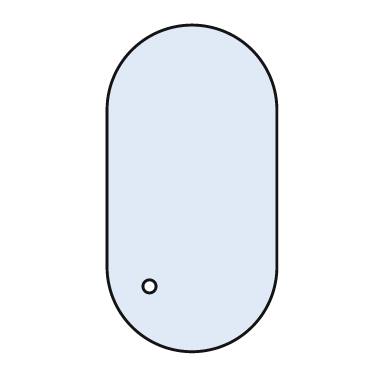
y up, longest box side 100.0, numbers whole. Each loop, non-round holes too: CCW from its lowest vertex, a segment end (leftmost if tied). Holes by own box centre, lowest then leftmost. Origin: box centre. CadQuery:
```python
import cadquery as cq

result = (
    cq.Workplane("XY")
    .moveTo(-26.0, -24.0)
    .threePointArc((0.0, -50.0), (26.0, -24.0))
    .lineTo(26.0, 24.0)
    .threePointArc((0.0, 50.0), (-26.0, 24.0))
    .close()
    .moveTo(-13.0, -30.0)
    .circle(2.0)
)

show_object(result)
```